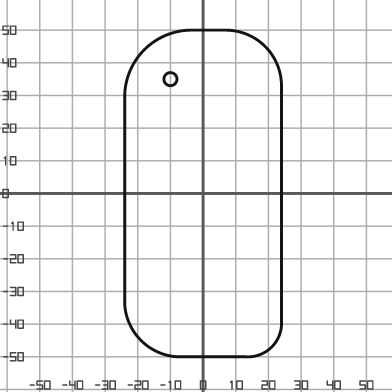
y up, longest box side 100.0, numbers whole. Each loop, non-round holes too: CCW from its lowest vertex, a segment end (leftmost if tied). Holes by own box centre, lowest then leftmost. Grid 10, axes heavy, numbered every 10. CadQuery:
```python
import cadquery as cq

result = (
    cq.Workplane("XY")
    .moveTo(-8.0, -50.0)
    .lineTo(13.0, -50.0)
    .threePointArc((21.0, -47.0), (24.0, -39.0))
    .lineTo(24.0, 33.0)
    .threePointArc((19.0, 45.0), (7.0, 50.0))
    .lineTo(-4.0, 50.0)
    .threePointArc((-18.0, 44.0), (-24.0, 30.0))
    .lineTo(-24.0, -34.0)
    .threePointArc((-19.0, -45.0), (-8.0, -50.0))
    .close()
    .moveTo(-10.0, 35.0)
    .circle(2.0)
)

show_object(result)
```